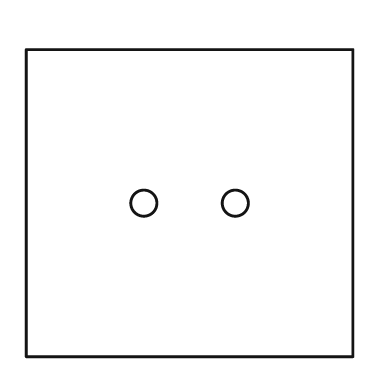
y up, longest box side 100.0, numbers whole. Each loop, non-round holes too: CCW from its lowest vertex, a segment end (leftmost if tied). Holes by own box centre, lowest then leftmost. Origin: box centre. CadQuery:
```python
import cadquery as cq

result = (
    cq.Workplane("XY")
    .moveTo(-50.0, -47.0)
    .lineTo(50.0, -47.0)
    .lineTo(50.0, 47.0)
    .lineTo(-50.0, 47.0)
    .close()
    .moveTo(-14.0, 0.0)
    .circle(4.0)
    .moveTo(14.0, 0.0)
    .circle(4.0)
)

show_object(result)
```